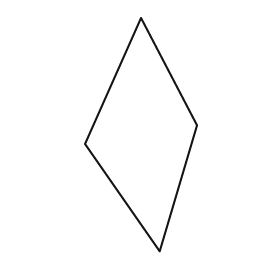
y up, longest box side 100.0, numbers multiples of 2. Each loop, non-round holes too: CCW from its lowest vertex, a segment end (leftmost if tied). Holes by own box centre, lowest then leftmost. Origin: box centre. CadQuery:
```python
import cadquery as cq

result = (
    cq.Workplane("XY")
    .moveTo(8.0, -50.0)
    .lineTo(24.0, 4.0)
    .lineTo(0.0, 50.0)
    .lineTo(-24.0, -4.0)
    .close()
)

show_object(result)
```